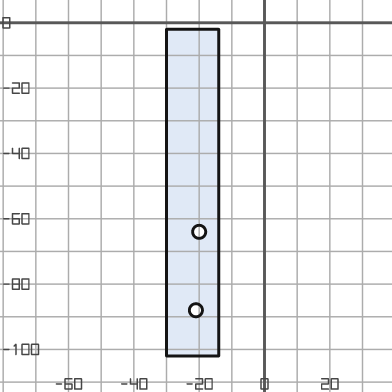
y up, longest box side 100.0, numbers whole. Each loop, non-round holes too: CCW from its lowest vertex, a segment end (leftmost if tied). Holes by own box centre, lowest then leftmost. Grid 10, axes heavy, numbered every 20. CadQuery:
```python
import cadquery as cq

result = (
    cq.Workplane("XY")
    .moveTo(-30.0, -102.0)
    .lineTo(-14.0, -102.0)
    .lineTo(-14.0, -2.0)
    .lineTo(-30.0, -2.0)
    .close()
    .moveTo(-21.0, -88.0)
    .circle(2.0)
    .moveTo(-20.0, -64.0)
    .circle(2.0)
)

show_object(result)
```